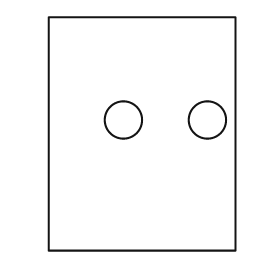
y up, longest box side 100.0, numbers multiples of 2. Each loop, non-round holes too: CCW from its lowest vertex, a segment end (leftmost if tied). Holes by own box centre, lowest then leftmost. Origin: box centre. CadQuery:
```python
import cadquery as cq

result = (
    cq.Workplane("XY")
    .moveTo(-40.0, -50.0)
    .lineTo(40.0, -50.0)
    .lineTo(40.0, 50.0)
    .lineTo(-40.0, 50.0)
    .close()
    .moveTo(-8.0, 6.0)
    .circle(8.0)
    .moveTo(28.0, 6.0)
    .circle(8.0)
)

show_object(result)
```